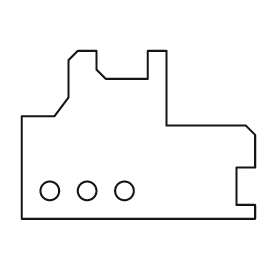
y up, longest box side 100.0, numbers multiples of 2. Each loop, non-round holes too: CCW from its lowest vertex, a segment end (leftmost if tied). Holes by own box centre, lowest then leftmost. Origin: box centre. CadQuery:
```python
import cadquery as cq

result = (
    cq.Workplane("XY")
    .moveTo(-50.0, -36.0)
    .lineTo(50.0, -36.0)
    .lineTo(50.0, -30.0)
    .lineTo(42.0, -30.0)
    .lineTo(42.0, -14.0)
    .lineTo(50.0, -14.0)
    .lineTo(50.0, 0.0)
    .lineTo(46.0, 4.0)
    .lineTo(12.0, 4.0)
    .lineTo(12.0, 36.0)
    .lineTo(4.0, 36.0)
    .lineTo(4.0, 24.0)
    .lineTo(-14.0, 24.0)
    .lineTo(-18.0, 28.0)
    .lineTo(-18.0, 36.0)
    .lineTo(-26.0, 36.0)
    .lineTo(-30.0, 32.0)
    .lineTo(-30.0, 16.0)
    .lineTo(-36.0, 8.0)
    .lineTo(-50.0, 8.0)
    .close()
    .moveTo(-38.0, -24.0)
    .circle(4.0)
    .moveTo(-22.0, -24.0)
    .circle(4.0)
    .moveTo(-6.0, -24.0)
    .circle(4.0)
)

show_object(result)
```